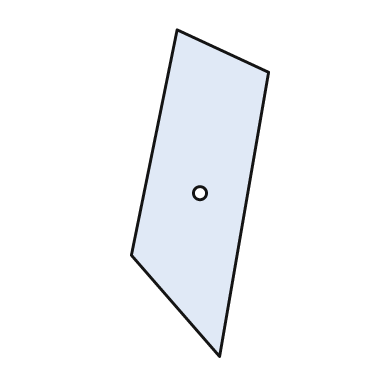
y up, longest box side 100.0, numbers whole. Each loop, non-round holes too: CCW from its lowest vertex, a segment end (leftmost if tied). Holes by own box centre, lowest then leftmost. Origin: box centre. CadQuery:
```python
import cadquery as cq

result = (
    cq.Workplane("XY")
    .moveTo(6.0, -50.0)
    .lineTo(21.0, 37.0)
    .lineTo(-7.0, 50.0)
    .lineTo(-21.0, -19.0)
    .close()
    .moveTo(0.0, 0.0)
    .circle(2.0)
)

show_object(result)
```